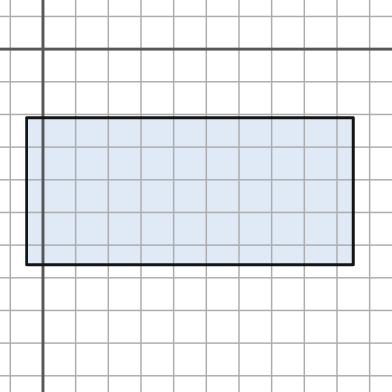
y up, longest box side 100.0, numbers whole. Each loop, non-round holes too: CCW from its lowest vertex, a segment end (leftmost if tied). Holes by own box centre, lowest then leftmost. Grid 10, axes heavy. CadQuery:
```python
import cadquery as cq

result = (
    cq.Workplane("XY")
    .moveTo(-5.0, -66.0)
    .lineTo(95.0, -66.0)
    .lineTo(95.0, -21.0)
    .lineTo(-5.0, -21.0)
    .close()
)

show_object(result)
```